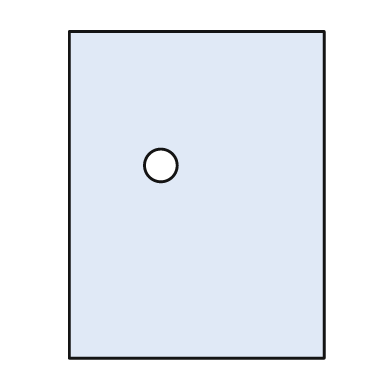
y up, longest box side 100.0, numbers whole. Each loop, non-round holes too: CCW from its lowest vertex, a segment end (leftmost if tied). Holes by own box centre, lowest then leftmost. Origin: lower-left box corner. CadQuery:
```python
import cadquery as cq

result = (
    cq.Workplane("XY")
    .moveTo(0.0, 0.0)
    .lineTo(78.0, 0.0)
    .lineTo(78.0, 100.0)
    .lineTo(0.0, 100.0)
    .close()
    .moveTo(28.0, 59.0)
    .circle(5.0)
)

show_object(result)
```